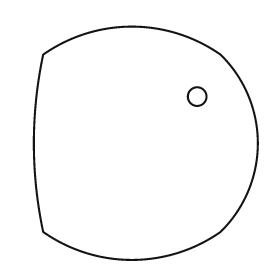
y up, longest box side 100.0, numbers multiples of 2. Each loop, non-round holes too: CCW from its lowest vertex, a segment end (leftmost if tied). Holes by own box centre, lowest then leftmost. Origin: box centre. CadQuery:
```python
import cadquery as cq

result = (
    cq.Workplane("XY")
    .moveTo(-44.0, -38.0)
    .threePointArc((-6.0, -50.0), (32.0, -38.0))
    .threePointArc((48.0, 0.0), (32.0, 38.0))
    .threePointArc((-6.0, 50.0), (-44.0, 38.0))
    .threePointArc((-48.0, 0.0), (-44.0, -38.0))
    .close()
    .moveTo(22.0, 20.0)
    .circle(4.0)
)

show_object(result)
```